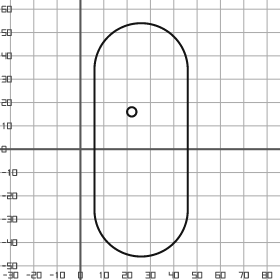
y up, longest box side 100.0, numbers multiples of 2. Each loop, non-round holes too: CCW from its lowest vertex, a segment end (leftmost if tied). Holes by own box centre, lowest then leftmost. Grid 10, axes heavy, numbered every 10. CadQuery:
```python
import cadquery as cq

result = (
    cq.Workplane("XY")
    .moveTo(6.0, -26.0)
    .threePointArc((26.0, -46.0), (46.0, -26.0))
    .lineTo(46.0, 34.0)
    .threePointArc((26.0, 54.0), (6.0, 34.0))
    .close()
    .moveTo(22.0, 16.0)
    .circle(2.0)
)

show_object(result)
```